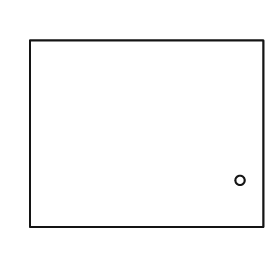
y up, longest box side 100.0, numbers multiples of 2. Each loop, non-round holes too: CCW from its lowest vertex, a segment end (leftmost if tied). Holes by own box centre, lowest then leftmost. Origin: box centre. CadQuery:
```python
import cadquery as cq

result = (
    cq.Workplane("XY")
    .moveTo(-50.0, -40.0)
    .lineTo(50.0, -40.0)
    .lineTo(50.0, 40.0)
    .lineTo(-50.0, 40.0)
    .close()
    .moveTo(40.0, -20.0)
    .circle(2.0)
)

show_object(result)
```